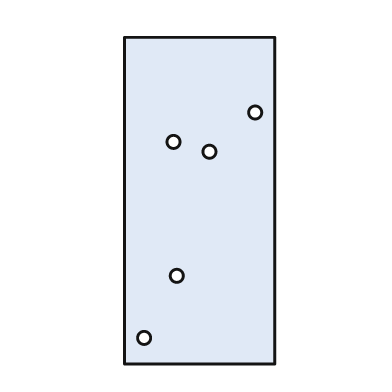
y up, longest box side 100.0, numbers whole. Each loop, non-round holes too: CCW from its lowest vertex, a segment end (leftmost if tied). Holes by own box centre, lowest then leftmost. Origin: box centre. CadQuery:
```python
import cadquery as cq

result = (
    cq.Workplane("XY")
    .moveTo(-23.0, -50.0)
    .lineTo(23.0, -50.0)
    .lineTo(23.0, 50.0)
    .lineTo(-23.0, 50.0)
    .close()
    .moveTo(-17.0, -42.0)
    .circle(2.0)
    .moveTo(-7.0, -23.0)
    .circle(2.0)
    .moveTo(3.0, 15.0)
    .circle(2.0)
    .moveTo(-8.0, 18.0)
    .circle(2.0)
    .moveTo(17.0, 27.0)
    .circle(2.0)
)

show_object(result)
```